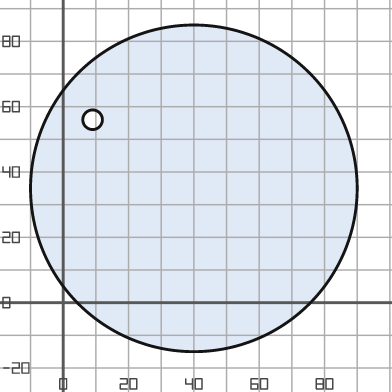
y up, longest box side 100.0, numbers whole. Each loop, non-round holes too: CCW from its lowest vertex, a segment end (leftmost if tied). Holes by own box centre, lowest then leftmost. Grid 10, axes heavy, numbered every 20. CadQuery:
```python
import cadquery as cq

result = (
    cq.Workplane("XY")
    .moveTo(40.0, 35.0)
    .circle(50.0)
    .moveTo(9.0, 56.0)
    .circle(3.0)
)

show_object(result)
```